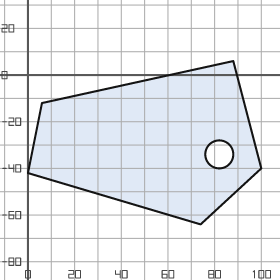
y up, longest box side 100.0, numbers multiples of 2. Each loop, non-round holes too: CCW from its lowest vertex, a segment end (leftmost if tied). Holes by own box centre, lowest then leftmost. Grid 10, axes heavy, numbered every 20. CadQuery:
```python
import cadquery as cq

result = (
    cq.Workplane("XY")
    .moveTo(74.0, -64.0)
    .lineTo(100.0, -40.0)
    .lineTo(88.0, 6.0)
    .lineTo(6.0, -12.0)
    .lineTo(0.0, -42.0)
    .close()
    .moveTo(82.0, -34.0)
    .circle(6.0)
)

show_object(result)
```